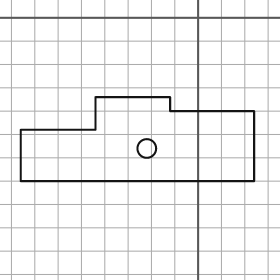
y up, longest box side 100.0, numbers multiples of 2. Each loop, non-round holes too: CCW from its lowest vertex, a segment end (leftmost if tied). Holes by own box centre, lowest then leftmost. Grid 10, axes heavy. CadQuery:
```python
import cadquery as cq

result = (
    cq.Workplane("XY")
    .moveTo(-76.0, -70.0)
    .lineTo(24.0, -70.0)
    .lineTo(24.0, -40.0)
    .lineTo(-12.0, -40.0)
    .lineTo(-12.0, -34.0)
    .lineTo(-44.0, -34.0)
    .lineTo(-44.0, -48.0)
    .lineTo(-76.0, -48.0)
    .close()
    .moveTo(-22.0, -56.0)
    .circle(4.0)
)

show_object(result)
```